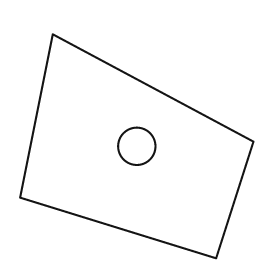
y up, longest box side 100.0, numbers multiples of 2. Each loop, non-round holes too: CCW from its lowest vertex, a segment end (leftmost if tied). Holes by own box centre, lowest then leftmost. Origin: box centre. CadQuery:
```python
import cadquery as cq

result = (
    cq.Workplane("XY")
    .moveTo(34.0, -48.0)
    .lineTo(50.0, 2.0)
    .lineTo(-36.0, 48.0)
    .lineTo(-50.0, -22.0)
    .close()
    .moveTo(0.0, 0.0)
    .circle(8.0)
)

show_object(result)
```